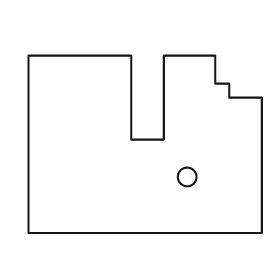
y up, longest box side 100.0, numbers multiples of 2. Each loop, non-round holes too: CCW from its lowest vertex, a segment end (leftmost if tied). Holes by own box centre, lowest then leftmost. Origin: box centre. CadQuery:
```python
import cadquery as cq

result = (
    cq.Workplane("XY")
    .moveTo(-50.0, -38.0)
    .lineTo(50.0, -38.0)
    .lineTo(50.0, 20.0)
    .lineTo(36.0, 20.0)
    .lineTo(36.0, 26.0)
    .lineTo(30.0, 26.0)
    .lineTo(30.0, 38.0)
    .lineTo(8.0, 38.0)
    .lineTo(8.0, 2.0)
    .lineTo(-6.0, 2.0)
    .lineTo(-6.0, 38.0)
    .lineTo(-50.0, 38.0)
    .close()
    .moveTo(18.0, -14.0)
    .circle(4.0)
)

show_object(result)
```